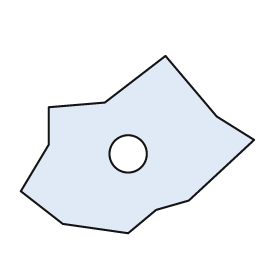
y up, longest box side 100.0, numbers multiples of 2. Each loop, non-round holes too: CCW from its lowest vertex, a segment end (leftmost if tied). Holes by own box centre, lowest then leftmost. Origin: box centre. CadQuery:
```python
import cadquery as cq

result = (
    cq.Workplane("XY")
    .moveTo(-4.0, -38.0)
    .lineTo(8.0, -28.0)
    .lineTo(22.0, -24.0)
    .lineTo(50.0, 2.0)
    .lineTo(34.0, 12.0)
    .lineTo(12.0, 38.0)
    .lineTo(-14.0, 18.0)
    .lineTo(-38.0, 16.0)
    .lineTo(-38.0, 0.0)
    .lineTo(-50.0, -20.0)
    .lineTo(-32.0, -34.0)
    .close()
    .moveTo(-4.0, -4.0)
    .circle(8.0)
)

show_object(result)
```